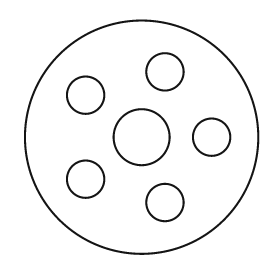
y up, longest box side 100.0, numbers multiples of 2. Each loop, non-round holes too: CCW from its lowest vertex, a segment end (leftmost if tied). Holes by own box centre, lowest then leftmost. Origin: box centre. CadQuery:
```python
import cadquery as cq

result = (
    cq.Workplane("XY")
    .moveTo(0.0, 0.0)
    .circle(50.0)
    .moveTo(10.0, -28.0)
    .circle(8.0)
    .moveTo(-24.0, -18.0)
    .circle(8.0)
    .moveTo(0.0, 0.0)
    .circle(12.0)
    .moveTo(30.0, 0.0)
    .circle(8.0)
    .moveTo(-24.0, 18.0)
    .circle(8.0)
    .moveTo(10.0, 28.0)
    .circle(8.0)
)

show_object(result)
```